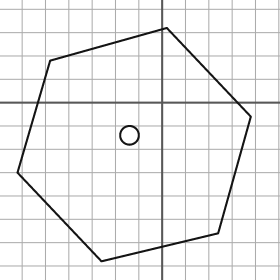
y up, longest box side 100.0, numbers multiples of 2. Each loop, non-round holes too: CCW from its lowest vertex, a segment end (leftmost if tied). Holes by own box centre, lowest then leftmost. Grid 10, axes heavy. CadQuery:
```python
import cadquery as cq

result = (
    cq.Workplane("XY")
    .moveTo(-26.0, -68.0)
    .lineTo(24.0, -56.0)
    .lineTo(38.0, -6.0)
    .lineTo(2.0, 32.0)
    .lineTo(-48.0, 18.0)
    .lineTo(-62.0, -30.0)
    .close()
    .moveTo(-14.0, -14.0)
    .circle(4.0)
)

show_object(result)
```